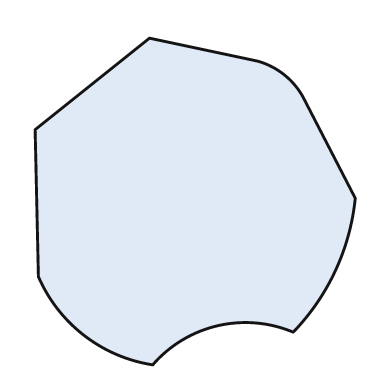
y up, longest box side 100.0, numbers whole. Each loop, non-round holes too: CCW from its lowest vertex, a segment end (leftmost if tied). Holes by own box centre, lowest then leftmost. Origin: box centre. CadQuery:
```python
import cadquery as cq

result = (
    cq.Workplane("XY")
    .moveTo(-13.0, -50.0)
    .threePointArc((7.0, -38.0), (30.0, -40.0))
    .threePointArc((43.0, -21.0), (49.0, 1.0))
    .lineTo(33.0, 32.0)
    .threePointArc((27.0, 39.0), (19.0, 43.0))
    .lineTo(-14.0, 50.0)
    .lineTo(-49.0, 22.0)
    .lineTo(-48.0, -23.0)
    .threePointArc((-34.0, -41.0), (-13.0, -50.0))
    .close()
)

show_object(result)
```